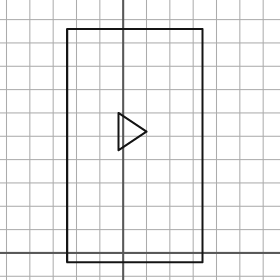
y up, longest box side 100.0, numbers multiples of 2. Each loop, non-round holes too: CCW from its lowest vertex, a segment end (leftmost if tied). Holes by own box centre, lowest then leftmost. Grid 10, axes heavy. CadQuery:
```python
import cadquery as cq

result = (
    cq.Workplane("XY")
    .moveTo(-24.0, -4.0)
    .lineTo(34.0, -4.0)
    .lineTo(34.0, 96.0)
    .lineTo(-24.0, 96.0)
    .close()
    .moveTo(-2.0, 44.0)
    .lineTo(10.0, 52.0)
    .lineTo(-2.0, 60.0)
    .close()
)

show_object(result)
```